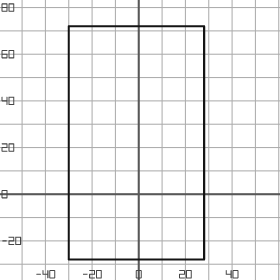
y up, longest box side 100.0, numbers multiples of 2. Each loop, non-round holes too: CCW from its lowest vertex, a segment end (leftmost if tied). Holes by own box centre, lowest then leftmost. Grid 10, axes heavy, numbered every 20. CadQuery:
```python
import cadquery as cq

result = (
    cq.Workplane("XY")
    .moveTo(-30.0, -28.0)
    .lineTo(28.0, -28.0)
    .lineTo(28.0, 72.0)
    .lineTo(-30.0, 72.0)
    .close()
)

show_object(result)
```